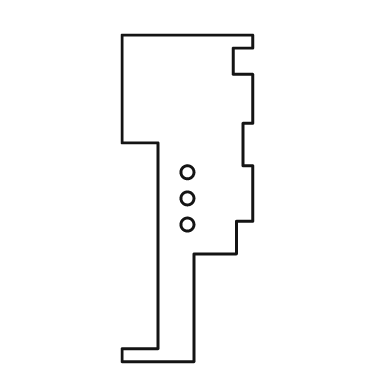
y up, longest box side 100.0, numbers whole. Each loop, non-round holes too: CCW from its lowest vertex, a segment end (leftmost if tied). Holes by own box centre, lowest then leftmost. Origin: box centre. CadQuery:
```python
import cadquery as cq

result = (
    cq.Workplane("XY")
    .moveTo(-20.0, -50.0)
    .lineTo(2.0, -50.0)
    .lineTo(2.0, -17.0)
    .lineTo(15.0, -17.0)
    .lineTo(15.0, -7.0)
    .lineTo(20.0, -7.0)
    .lineTo(20.0, 10.0)
    .lineTo(17.0, 10.0)
    .lineTo(17.0, 23.0)
    .lineTo(20.0, 23.0)
    .lineTo(20.0, 38.0)
    .lineTo(14.0, 38.0)
    .lineTo(14.0, 46.0)
    .lineTo(20.0, 46.0)
    .lineTo(20.0, 50.0)
    .lineTo(-20.0, 50.0)
    .lineTo(-20.0, 17.0)
    .lineTo(-9.0, 17.0)
    .lineTo(-9.0, -46.0)
    .lineTo(-20.0, -46.0)
    .close()
    .moveTo(0.0, -8.0)
    .circle(2.0)
    .moveTo(0.0, 0.0)
    .circle(2.0)
    .moveTo(0.0, 8.0)
    .circle(2.0)
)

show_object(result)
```